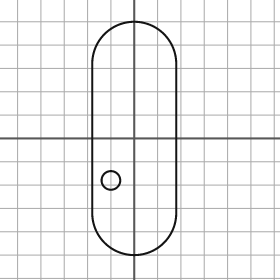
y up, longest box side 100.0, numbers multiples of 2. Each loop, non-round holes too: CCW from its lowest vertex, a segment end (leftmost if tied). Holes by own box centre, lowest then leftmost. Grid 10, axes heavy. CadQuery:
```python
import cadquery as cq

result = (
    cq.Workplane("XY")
    .moveTo(-18.0, -32.0)
    .threePointArc((0.0, -50.0), (18.0, -32.0))
    .lineTo(18.0, 32.0)
    .threePointArc((0.0, 50.0), (-18.0, 32.0))
    .close()
    .moveTo(-10.0, -18.0)
    .circle(4.0)
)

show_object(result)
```